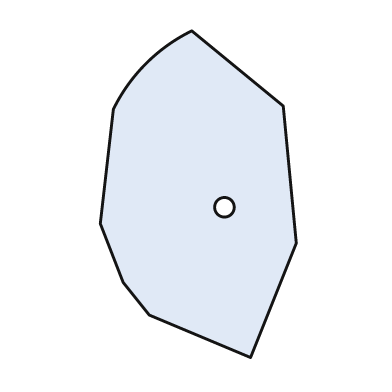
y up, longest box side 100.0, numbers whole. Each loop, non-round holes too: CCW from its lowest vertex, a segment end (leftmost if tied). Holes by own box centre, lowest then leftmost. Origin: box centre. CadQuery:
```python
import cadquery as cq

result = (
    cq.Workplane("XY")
    .moveTo(16.0, -50.0)
    .lineTo(30.0, -15.0)
    .lineTo(26.0, 27.0)
    .lineTo(-2.0, 50.0)
    .threePointArc((-16.0, 40.0), (-26.0, 26.0))
    .lineTo(-30.0, -9.0)
    .lineTo(-23.0, -27.0)
    .lineTo(-15.0, -37.0)
    .close()
    .moveTo(8.0, -4.0)
    .circle(3.0)
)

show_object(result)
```